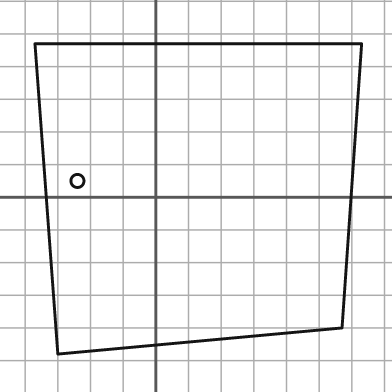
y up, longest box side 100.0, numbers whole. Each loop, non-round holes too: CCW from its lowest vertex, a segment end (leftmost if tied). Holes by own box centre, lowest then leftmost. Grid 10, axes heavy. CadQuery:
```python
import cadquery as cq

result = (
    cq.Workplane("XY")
    .moveTo(-30.0, -48.0)
    .lineTo(57.0, -40.0)
    .lineTo(63.0, 47.0)
    .lineTo(-37.0, 47.0)
    .close()
    .moveTo(-24.0, 5.0)
    .circle(2.0)
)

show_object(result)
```